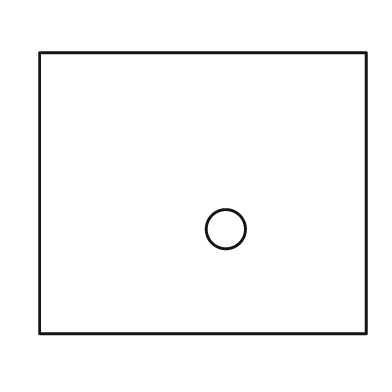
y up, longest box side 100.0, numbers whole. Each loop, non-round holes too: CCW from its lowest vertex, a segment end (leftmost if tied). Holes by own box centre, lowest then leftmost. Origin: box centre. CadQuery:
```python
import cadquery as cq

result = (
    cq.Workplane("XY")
    .moveTo(-50.0, -43.0)
    .lineTo(50.0, -43.0)
    .lineTo(50.0, 43.0)
    .lineTo(-50.0, 43.0)
    .close()
    .moveTo(7.0, -11.0)
    .circle(6.0)
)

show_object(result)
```